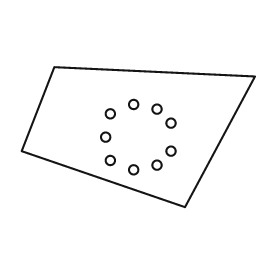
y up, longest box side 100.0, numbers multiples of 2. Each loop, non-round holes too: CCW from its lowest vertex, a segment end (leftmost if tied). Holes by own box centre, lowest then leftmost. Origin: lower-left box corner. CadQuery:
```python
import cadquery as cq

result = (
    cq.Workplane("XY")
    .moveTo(70.0, 0.0)
    .lineTo(100.0, 56.0)
    .lineTo(14.0, 60.0)
    .lineTo(0.0, 24.0)
    .close()
    .moveTo(48.0, 16.0)
    .circle(2.0)
    .moveTo(58.0, 18.0)
    .circle(2.0)
    .moveTo(38.0, 20.0)
    .circle(2.0)
    .moveTo(64.0, 24.0)
    .circle(2.0)
    .moveTo(36.0, 30.0)
    .circle(2.0)
    .moveTo(64.0, 36.0)
    .circle(2.0)
    .moveTo(38.0, 40.0)
    .circle(2.0)
    .moveTo(58.0, 42.0)
    .circle(2.0)
    .moveTo(48.0, 44.0)
    .circle(2.0)
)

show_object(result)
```